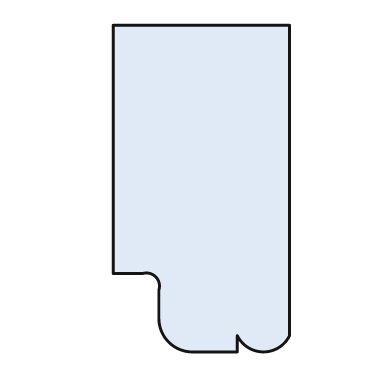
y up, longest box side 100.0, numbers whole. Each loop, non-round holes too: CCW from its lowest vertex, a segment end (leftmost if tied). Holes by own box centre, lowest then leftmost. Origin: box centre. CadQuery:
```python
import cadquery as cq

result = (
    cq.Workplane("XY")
    .moveTo(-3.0, -50.0)
    .lineTo(11.0, -50.0)
    .lineTo(11.0, -45.0)
    .threePointArc((19.0, -50.0), (27.0, -45.0))
    .lineTo(27.0, 50.0)
    .lineTo(-27.0, 50.0)
    .lineTo(-27.0, -26.0)
    .lineTo(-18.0, -26.0)
    .threePointArc((-14.0, -27.0), (-13.0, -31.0))
    .lineTo(-13.0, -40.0)
    .threePointArc((-10.0, -47.0), (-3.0, -50.0))
    .close()
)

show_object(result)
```